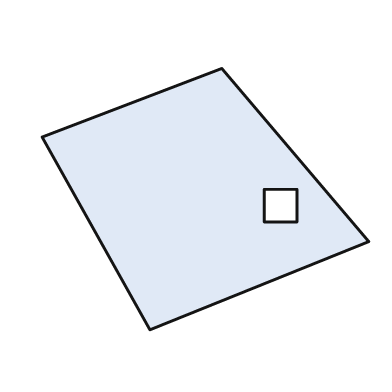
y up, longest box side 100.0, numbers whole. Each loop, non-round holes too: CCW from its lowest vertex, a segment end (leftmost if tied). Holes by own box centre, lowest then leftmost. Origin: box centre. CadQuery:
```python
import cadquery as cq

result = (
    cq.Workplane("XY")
    .moveTo(-17.0, -40.0)
    .lineTo(50.0, -13.0)
    .lineTo(5.0, 40.0)
    .lineTo(-50.0, 19.0)
    .close()
    .moveTo(18.0, -7.0)
    .lineTo(28.0, -7.0)
    .lineTo(28.0, 3.0)
    .lineTo(18.0, 3.0)
    .close()
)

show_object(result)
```